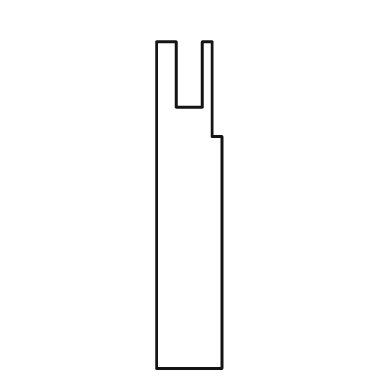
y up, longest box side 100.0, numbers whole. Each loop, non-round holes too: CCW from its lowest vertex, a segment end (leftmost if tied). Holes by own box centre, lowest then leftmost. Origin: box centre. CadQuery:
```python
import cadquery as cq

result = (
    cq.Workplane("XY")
    .moveTo(-10.0, -50.0)
    .lineTo(10.0, -50.0)
    .lineTo(10.0, 21.0)
    .lineTo(7.0, 21.0)
    .lineTo(7.0, 50.0)
    .lineTo(4.0, 50.0)
    .lineTo(4.0, 30.0)
    .lineTo(-4.0, 30.0)
    .lineTo(-4.0, 50.0)
    .lineTo(-10.0, 50.0)
    .close()
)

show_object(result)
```